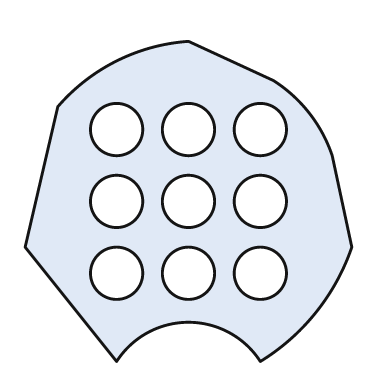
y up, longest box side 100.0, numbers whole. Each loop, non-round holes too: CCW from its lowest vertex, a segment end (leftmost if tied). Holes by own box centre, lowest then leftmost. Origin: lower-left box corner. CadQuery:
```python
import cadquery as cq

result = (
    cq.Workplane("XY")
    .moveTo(28.0, 0.0)
    .threePointArc((50.0, 12.0), (72.0, 0.0))
    .threePointArc((89.0, 15.0), (100.0, 35.0))
    .lineTo(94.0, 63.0)
    .threePointArc((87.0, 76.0), (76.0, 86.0))
    .lineTo(50.0, 98.0)
    .threePointArc((28.0, 92.0), (10.0, 78.0))
    .lineTo(0.0, 35.0)
    .close()
    .moveTo(28.0, 27.0)
    .circle(8.0)
    .moveTo(50.0, 27.0)
    .circle(8.0)
    .moveTo(72.0, 27.0)
    .circle(8.0)
    .moveTo(28.0, 49.0)
    .circle(8.0)
    .moveTo(50.0, 49.0)
    .circle(8.0)
    .moveTo(72.0, 49.0)
    .circle(8.0)
    .moveTo(28.0, 71.0)
    .circle(8.0)
    .moveTo(50.0, 71.0)
    .circle(8.0)
    .moveTo(72.0, 71.0)
    .circle(8.0)
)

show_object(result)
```